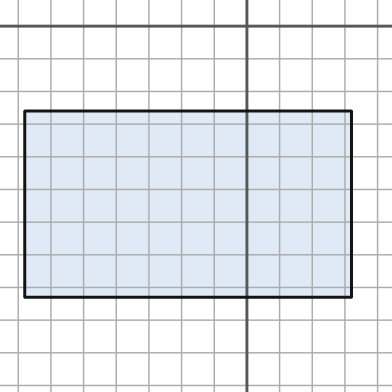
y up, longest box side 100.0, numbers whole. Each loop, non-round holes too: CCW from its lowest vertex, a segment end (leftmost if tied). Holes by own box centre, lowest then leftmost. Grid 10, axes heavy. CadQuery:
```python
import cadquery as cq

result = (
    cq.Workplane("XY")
    .moveTo(-68.0, -83.0)
    .lineTo(32.0, -83.0)
    .lineTo(32.0, -26.0)
    .lineTo(-68.0, -26.0)
    .close()
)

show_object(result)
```